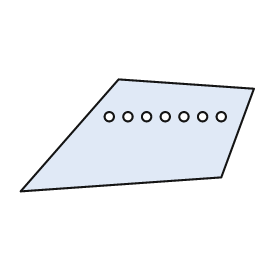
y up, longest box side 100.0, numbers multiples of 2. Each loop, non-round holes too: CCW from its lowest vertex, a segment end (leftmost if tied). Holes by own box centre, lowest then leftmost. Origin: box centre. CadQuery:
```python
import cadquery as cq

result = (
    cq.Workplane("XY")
    .moveTo(-50.0, -24.0)
    .lineTo(36.0, -18.0)
    .lineTo(50.0, 20.0)
    .lineTo(-8.0, 24.0)
    .close()
    .moveTo(-12.0, 8.0)
    .circle(2.0)
    .moveTo(-4.0, 8.0)
    .circle(2.0)
    .moveTo(4.0, 8.0)
    .circle(2.0)
    .moveTo(12.0, 8.0)
    .circle(2.0)
    .moveTo(20.0, 8.0)
    .circle(2.0)
    .moveTo(28.0, 8.0)
    .circle(2.0)
    .moveTo(36.0, 8.0)
    .circle(2.0)
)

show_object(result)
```